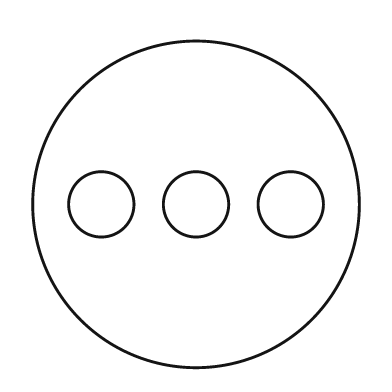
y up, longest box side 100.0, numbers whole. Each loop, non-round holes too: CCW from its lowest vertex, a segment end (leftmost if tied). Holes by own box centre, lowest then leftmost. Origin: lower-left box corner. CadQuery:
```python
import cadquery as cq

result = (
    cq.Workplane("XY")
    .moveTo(50.0, 50.0)
    .circle(50.0)
    .moveTo(21.0, 50.0)
    .circle(10.0)
    .moveTo(50.0, 50.0)
    .circle(10.0)
    .moveTo(79.0, 50.0)
    .circle(10.0)
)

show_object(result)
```